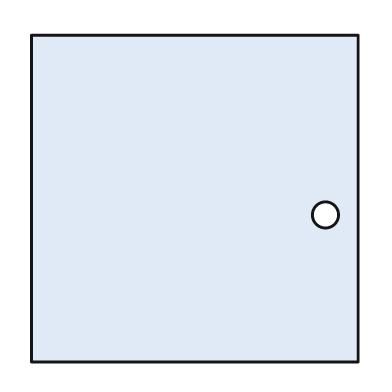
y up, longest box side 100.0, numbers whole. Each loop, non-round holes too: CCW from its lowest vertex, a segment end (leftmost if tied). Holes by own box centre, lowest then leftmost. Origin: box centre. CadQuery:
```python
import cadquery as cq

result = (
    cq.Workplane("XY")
    .moveTo(-50.0, -50.0)
    .lineTo(50.0, -50.0)
    .lineTo(50.0, 50.0)
    .lineTo(-50.0, 50.0)
    .close()
    .moveTo(40.0, -5.0)
    .circle(4.0)
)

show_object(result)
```